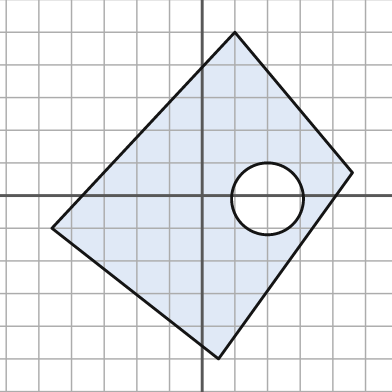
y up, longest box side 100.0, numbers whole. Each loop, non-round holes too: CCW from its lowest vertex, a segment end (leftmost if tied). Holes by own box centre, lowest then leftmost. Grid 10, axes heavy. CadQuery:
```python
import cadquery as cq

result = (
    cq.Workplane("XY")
    .moveTo(5.0, -50.0)
    .lineTo(46.0, 7.0)
    .lineTo(10.0, 50.0)
    .lineTo(-46.0, -10.0)
    .close()
    .moveTo(20.0, -1.0)
    .circle(11.0)
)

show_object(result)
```